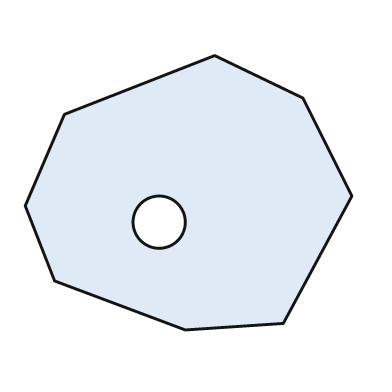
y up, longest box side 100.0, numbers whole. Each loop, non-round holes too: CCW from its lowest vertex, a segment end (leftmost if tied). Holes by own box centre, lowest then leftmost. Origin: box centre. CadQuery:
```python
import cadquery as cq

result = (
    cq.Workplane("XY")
    .moveTo(-1.0, -42.0)
    .lineTo(29.0, -40.0)
    .lineTo(50.0, -1.0)
    .lineTo(35.0, 29.0)
    .lineTo(8.0, 42.0)
    .lineTo(-38.0, 24.0)
    .lineTo(-50.0, -4.0)
    .lineTo(-41.0, -27.0)
    .close()
    .moveTo(-9.0, -9.0)
    .circle(8.0)
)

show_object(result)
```